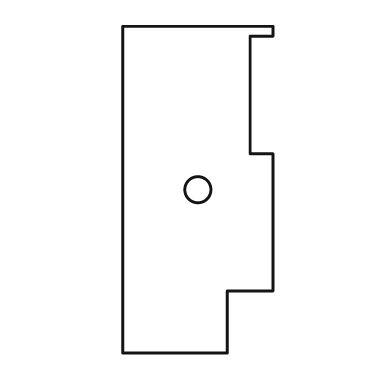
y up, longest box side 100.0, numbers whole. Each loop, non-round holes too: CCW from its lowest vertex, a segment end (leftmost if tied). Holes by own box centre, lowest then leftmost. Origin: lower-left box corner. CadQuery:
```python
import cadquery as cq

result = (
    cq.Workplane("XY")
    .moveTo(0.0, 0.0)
    .lineTo(32.0, 0.0)
    .lineTo(32.0, 19.0)
    .lineTo(46.0, 19.0)
    .lineTo(46.0, 61.0)
    .lineTo(39.0, 61.0)
    .lineTo(39.0, 97.0)
    .lineTo(46.0, 97.0)
    .lineTo(46.0, 100.0)
    .lineTo(0.0, 100.0)
    .close()
    .moveTo(23.0, 50.0)
    .circle(4.0)
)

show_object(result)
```